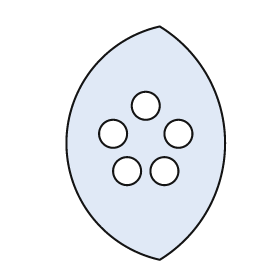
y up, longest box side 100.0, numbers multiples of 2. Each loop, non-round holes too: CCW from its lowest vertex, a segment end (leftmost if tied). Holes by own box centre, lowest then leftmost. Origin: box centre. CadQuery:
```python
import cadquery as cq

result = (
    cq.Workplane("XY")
    .moveTo(6.0, -50.0)
    .threePointArc((34.0, 0.0), (6.0, 50.0))
    .threePointArc((-34.0, 0.0), (6.0, -50.0))
    .close()
    .moveTo(-8.0, -12.0)
    .circle(6.0)
    .moveTo(8.0, -12.0)
    .circle(6.0)
    .moveTo(-14.0, 4.0)
    .circle(6.0)
    .moveTo(14.0, 4.0)
    .circle(6.0)
    .moveTo(0.0, 16.0)
    .circle(6.0)
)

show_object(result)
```